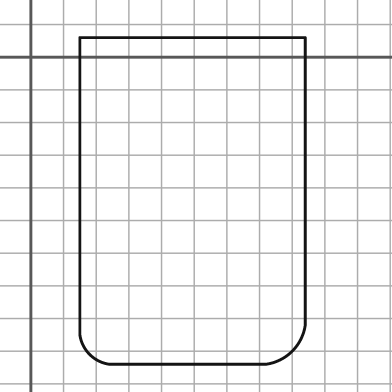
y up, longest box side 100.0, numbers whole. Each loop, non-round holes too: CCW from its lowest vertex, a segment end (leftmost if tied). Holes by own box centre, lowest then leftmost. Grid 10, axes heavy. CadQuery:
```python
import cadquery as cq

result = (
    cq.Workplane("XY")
    .moveTo(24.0, -94.0)
    .lineTo(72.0, -94.0)
    .threePointArc((80.0, -90.0), (84.0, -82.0))
    .lineTo(84.0, 6.0)
    .lineTo(15.0, 6.0)
    .lineTo(15.0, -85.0)
    .threePointArc((18.0, -91.0), (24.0, -94.0))
    .close()
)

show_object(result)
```